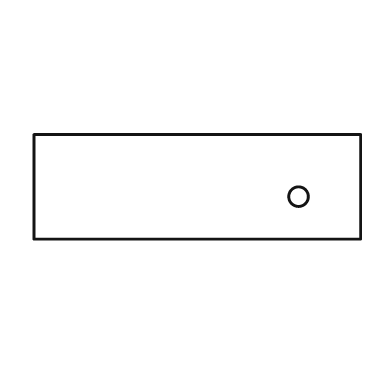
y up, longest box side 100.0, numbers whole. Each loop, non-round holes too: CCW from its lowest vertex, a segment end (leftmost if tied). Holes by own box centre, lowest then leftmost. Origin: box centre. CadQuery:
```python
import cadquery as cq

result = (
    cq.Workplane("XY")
    .moveTo(-50.0, -16.0)
    .lineTo(50.0, -16.0)
    .lineTo(50.0, 16.0)
    .lineTo(-50.0, 16.0)
    .close()
    .moveTo(31.0, -3.0)
    .circle(3.0)
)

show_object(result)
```